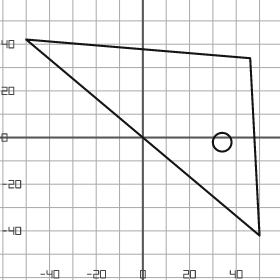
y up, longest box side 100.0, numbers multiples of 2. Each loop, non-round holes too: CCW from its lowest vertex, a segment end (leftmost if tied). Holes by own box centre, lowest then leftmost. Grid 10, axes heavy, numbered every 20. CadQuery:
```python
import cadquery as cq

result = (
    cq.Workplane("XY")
    .moveTo(50.0, -42.0)
    .lineTo(46.0, 34.0)
    .lineTo(-50.0, 42.0)
    .close()
    .moveTo(34.0, -2.0)
    .circle(4.0)
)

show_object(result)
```